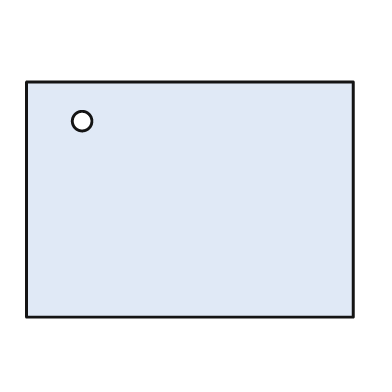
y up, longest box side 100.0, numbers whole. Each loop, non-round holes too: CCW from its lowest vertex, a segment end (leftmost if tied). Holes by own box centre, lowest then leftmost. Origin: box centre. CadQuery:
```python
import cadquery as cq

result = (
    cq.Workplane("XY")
    .moveTo(-50.0, -36.0)
    .lineTo(50.0, -36.0)
    .lineTo(50.0, 36.0)
    .lineTo(-50.0, 36.0)
    .close()
    .moveTo(-33.0, 24.0)
    .circle(3.0)
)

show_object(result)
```